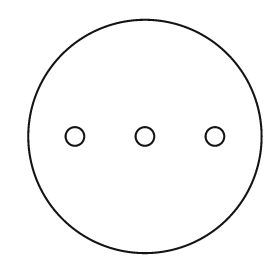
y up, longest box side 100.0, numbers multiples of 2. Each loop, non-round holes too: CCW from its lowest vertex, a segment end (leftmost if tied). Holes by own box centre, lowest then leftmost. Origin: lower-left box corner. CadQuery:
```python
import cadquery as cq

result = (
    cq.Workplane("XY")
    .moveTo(50.0, 50.0)
    .circle(50.0)
    .moveTo(20.0, 50.0)
    .circle(4.0)
    .moveTo(50.0, 50.0)
    .circle(4.0)
    .moveTo(80.0, 50.0)
    .circle(4.0)
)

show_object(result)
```